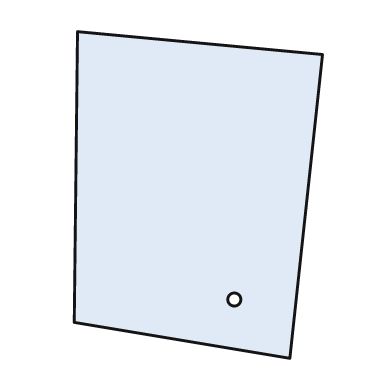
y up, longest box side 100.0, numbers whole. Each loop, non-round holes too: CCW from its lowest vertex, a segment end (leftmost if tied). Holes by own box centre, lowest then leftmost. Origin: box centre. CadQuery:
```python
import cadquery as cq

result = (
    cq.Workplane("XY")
    .moveTo(28.0, -50.0)
    .lineTo(38.0, 43.0)
    .lineTo(-37.0, 50.0)
    .lineTo(-38.0, -39.0)
    .close()
    .moveTo(11.0, -32.0)
    .circle(2.0)
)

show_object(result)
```